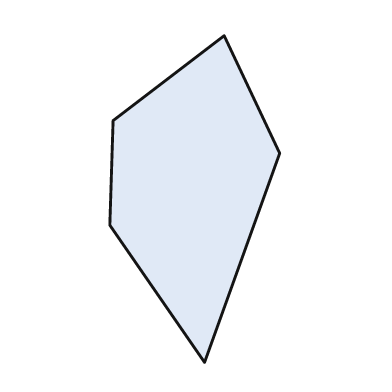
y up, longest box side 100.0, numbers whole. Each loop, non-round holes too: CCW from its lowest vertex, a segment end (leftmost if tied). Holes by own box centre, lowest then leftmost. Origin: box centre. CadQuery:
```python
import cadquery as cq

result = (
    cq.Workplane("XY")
    .moveTo(3.0, -50.0)
    .lineTo(26.0, 14.0)
    .lineTo(9.0, 50.0)
    .lineTo(-25.0, 24.0)
    .lineTo(-26.0, -8.0)
    .close()
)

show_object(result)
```